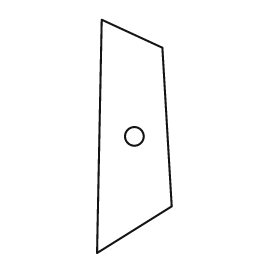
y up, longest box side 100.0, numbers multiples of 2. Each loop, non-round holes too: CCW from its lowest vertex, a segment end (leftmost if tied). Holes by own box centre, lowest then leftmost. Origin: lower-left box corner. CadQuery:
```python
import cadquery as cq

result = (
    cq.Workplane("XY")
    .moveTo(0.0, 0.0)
    .lineTo(32.0, 20.0)
    .lineTo(28.0, 88.0)
    .lineTo(2.0, 100.0)
    .close()
    .moveTo(16.0, 50.0)
    .circle(4.0)
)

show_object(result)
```